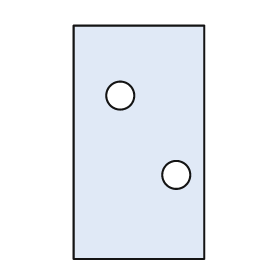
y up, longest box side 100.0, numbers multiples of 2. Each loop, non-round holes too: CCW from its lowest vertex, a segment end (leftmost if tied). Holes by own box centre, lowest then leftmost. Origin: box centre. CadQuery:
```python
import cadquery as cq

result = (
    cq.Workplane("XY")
    .moveTo(-28.0, -50.0)
    .lineTo(28.0, -50.0)
    .lineTo(28.0, 50.0)
    .lineTo(-28.0, 50.0)
    .close()
    .moveTo(16.0, -14.0)
    .circle(6.0)
    .moveTo(-8.0, 20.0)
    .circle(6.0)
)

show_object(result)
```